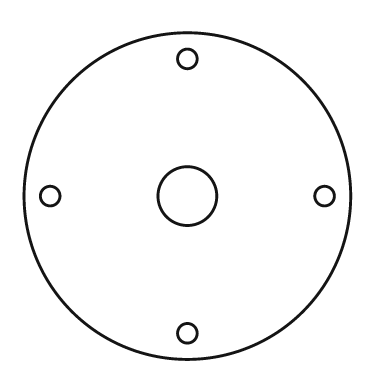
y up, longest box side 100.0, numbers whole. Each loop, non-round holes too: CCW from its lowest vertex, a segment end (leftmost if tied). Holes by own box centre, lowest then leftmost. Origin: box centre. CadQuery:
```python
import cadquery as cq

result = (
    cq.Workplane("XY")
    .moveTo(0.0, 0.0)
    .circle(50.0)
    .moveTo(0.0, -42.0)
    .circle(3.0)
    .moveTo(-42.0, 0.0)
    .circle(3.0)
    .moveTo(0.0, 0.0)
    .circle(9.0)
    .moveTo(42.0, 0.0)
    .circle(3.0)
    .moveTo(0.0, 42.0)
    .circle(3.0)
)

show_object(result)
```